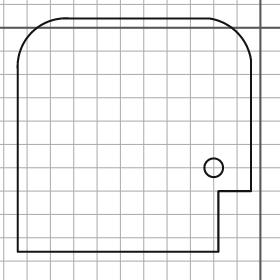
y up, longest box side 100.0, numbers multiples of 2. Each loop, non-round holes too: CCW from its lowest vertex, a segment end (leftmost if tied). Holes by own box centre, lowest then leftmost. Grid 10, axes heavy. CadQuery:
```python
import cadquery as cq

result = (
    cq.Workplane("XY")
    .moveTo(-104.0, -96.0)
    .lineTo(-18.0, -96.0)
    .lineTo(-18.0, -70.0)
    .lineTo(-4.0, -70.0)
    .lineTo(-4.0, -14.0)
    .threePointArc((-10.0, -2.0), (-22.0, 4.0))
    .lineTo(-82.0, 4.0)
    .threePointArc((-98.0, -2.0), (-104.0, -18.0))
    .close()
    .moveTo(-20.0, -60.0)
    .circle(4.0)
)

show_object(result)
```